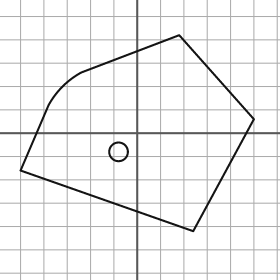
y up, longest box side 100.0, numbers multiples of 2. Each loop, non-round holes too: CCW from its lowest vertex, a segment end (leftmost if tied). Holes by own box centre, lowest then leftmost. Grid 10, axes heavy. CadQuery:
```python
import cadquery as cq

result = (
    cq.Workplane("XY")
    .moveTo(24.0, -42.0)
    .lineTo(50.0, 6.0)
    .lineTo(18.0, 42.0)
    .lineTo(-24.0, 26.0)
    .threePointArc((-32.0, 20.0), (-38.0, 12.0))
    .lineTo(-50.0, -16.0)
    .close()
    .moveTo(-8.0, -8.0)
    .circle(4.0)
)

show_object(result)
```